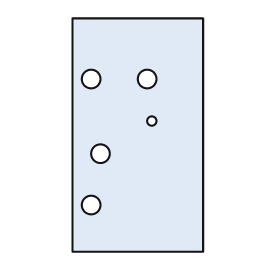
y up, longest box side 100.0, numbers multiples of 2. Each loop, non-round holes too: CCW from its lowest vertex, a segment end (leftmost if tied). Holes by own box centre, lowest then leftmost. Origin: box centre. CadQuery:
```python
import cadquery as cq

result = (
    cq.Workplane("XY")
    .moveTo(-28.0, -50.0)
    .lineTo(28.0, -50.0)
    .lineTo(28.0, 50.0)
    .lineTo(-28.0, 50.0)
    .close()
    .moveTo(-20.0, -30.0)
    .circle(4.0)
    .moveTo(-16.0, -8.0)
    .circle(4.0)
    .moveTo(6.0, 6.0)
    .circle(2.0)
    .moveTo(-20.0, 24.0)
    .circle(4.0)
    .moveTo(4.0, 24.0)
    .circle(4.0)
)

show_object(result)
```